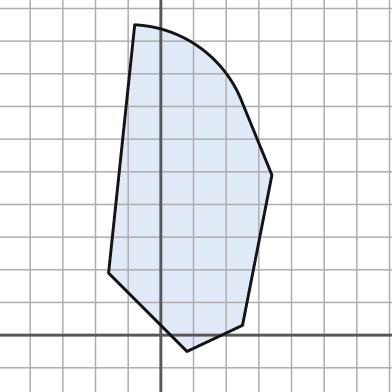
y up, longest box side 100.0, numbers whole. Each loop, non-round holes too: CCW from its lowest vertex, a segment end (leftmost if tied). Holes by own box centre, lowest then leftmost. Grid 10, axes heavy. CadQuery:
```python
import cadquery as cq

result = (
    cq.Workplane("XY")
    .moveTo(8.0, -5.0)
    .lineTo(25.0, 3.0)
    .lineTo(34.0, 49.0)
    .lineTo(25.0, 71.0)
    .threePointArc((12.0, 88.0), (-8.0, 95.0))
    .lineTo(-16.0, 19.0)
    .close()
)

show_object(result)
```